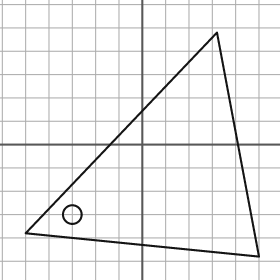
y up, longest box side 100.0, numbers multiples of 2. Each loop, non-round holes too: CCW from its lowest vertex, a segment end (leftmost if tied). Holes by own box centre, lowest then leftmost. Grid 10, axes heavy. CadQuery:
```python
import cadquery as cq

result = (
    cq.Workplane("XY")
    .moveTo(50.0, -48.0)
    .lineTo(32.0, 48.0)
    .lineTo(-50.0, -38.0)
    .close()
    .moveTo(-30.0, -30.0)
    .circle(4.0)
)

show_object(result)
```